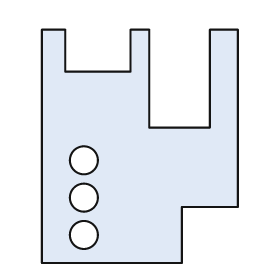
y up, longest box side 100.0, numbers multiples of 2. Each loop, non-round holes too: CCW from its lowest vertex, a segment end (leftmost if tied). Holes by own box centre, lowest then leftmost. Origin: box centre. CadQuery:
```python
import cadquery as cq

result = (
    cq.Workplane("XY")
    .moveTo(-42.0, -50.0)
    .lineTo(18.0, -50.0)
    .lineTo(18.0, -26.0)
    .lineTo(42.0, -26.0)
    .lineTo(42.0, 50.0)
    .lineTo(30.0, 50.0)
    .lineTo(30.0, 8.0)
    .lineTo(4.0, 8.0)
    .lineTo(4.0, 50.0)
    .lineTo(-4.0, 50.0)
    .lineTo(-4.0, 32.0)
    .lineTo(-32.0, 32.0)
    .lineTo(-32.0, 50.0)
    .lineTo(-42.0, 50.0)
    .close()
    .moveTo(-24.0, -38.0)
    .circle(6.0)
    .moveTo(-24.0, -22.0)
    .circle(6.0)
    .moveTo(-24.0, -6.0)
    .circle(6.0)
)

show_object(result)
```